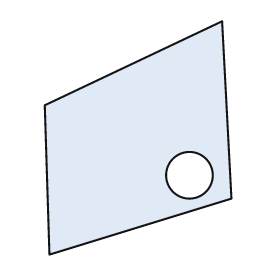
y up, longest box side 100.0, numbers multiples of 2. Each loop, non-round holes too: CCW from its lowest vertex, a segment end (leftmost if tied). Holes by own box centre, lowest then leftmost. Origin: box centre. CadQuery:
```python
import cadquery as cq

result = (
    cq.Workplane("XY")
    .moveTo(-38.0, -50.0)
    .lineTo(40.0, -26.0)
    .lineTo(36.0, 50.0)
    .lineTo(-40.0, 14.0)
    .close()
    .moveTo(22.0, -16.0)
    .circle(10.0)
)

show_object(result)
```